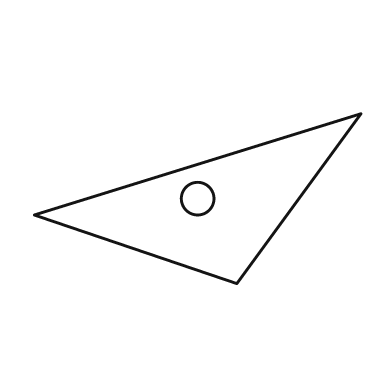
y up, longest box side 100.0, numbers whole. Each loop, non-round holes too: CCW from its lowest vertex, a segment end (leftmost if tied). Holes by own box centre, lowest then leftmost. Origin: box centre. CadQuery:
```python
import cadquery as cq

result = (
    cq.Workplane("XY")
    .moveTo(12.0, -26.0)
    .lineTo(50.0, 26.0)
    .lineTo(-50.0, -5.0)
    .close()
    .moveTo(0.0, 0.0)
    .circle(5.0)
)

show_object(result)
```